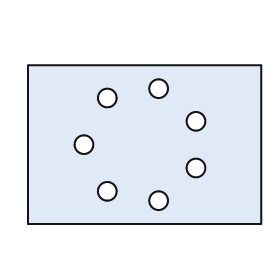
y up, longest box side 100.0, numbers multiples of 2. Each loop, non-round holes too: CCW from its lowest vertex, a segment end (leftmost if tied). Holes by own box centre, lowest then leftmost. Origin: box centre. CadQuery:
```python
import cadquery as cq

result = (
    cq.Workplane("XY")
    .moveTo(-50.0, -34.0)
    .lineTo(50.0, -34.0)
    .lineTo(50.0, 34.0)
    .lineTo(-50.0, 34.0)
    .close()
    .moveTo(6.0, -24.0)
    .circle(4.0)
    .moveTo(-16.0, -20.0)
    .circle(4.0)
    .moveTo(22.0, -10.0)
    .circle(4.0)
    .moveTo(-26.0, 0.0)
    .circle(4.0)
    .moveTo(22.0, 10.0)
    .circle(4.0)
    .moveTo(-16.0, 20.0)
    .circle(4.0)
    .moveTo(6.0, 24.0)
    .circle(4.0)
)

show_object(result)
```